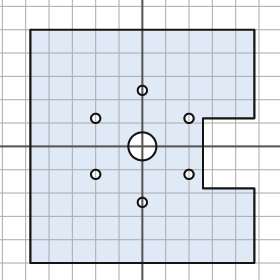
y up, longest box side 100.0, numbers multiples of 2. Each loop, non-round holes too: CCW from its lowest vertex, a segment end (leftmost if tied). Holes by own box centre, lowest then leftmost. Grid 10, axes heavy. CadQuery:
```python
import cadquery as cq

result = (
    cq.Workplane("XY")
    .moveTo(-48.0, -50.0)
    .lineTo(48.0, -50.0)
    .lineTo(48.0, -18.0)
    .lineTo(26.0, -18.0)
    .lineTo(26.0, 12.0)
    .lineTo(48.0, 12.0)
    .lineTo(48.0, 50.0)
    .lineTo(-48.0, 50.0)
    .close()
    .moveTo(0.0, -24.0)
    .circle(2.0)
    .moveTo(-20.0, -12.0)
    .circle(2.0)
    .moveTo(20.0, -12.0)
    .circle(2.0)
    .moveTo(0.0, 0.0)
    .circle(6.0)
    .moveTo(-20.0, 12.0)
    .circle(2.0)
    .moveTo(20.0, 12.0)
    .circle(2.0)
    .moveTo(0.0, 24.0)
    .circle(2.0)
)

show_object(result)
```